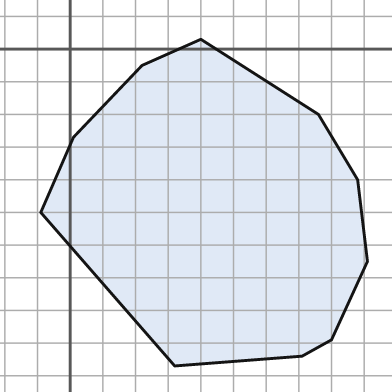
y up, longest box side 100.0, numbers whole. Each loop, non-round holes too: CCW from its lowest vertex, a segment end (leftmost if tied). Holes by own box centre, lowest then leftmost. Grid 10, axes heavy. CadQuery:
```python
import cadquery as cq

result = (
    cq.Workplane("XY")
    .moveTo(32.0, -97.0)
    .lineTo(71.0, -94.0)
    .lineTo(80.0, -89.0)
    .lineTo(91.0, -65.0)
    .lineTo(88.0, -40.0)
    .lineTo(76.0, -20.0)
    .lineTo(40.0, 3.0)
    .lineTo(22.0, -5.0)
    .lineTo(1.0, -27.0)
    .lineTo(-9.0, -50.0)
    .close()
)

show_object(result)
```